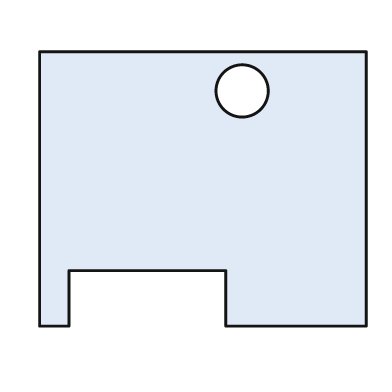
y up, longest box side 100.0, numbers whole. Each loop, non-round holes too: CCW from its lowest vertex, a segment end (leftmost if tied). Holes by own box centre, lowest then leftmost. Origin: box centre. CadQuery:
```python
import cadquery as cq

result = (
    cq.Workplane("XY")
    .moveTo(-50.0, -42.0)
    .lineTo(-41.0, -42.0)
    .lineTo(-41.0, -25.0)
    .lineTo(7.0, -25.0)
    .lineTo(7.0, -42.0)
    .lineTo(50.0, -42.0)
    .lineTo(50.0, 42.0)
    .lineTo(-50.0, 42.0)
    .close()
    .moveTo(12.0, 30.0)
    .circle(8.0)
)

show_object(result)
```